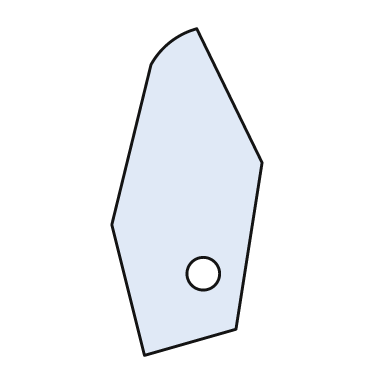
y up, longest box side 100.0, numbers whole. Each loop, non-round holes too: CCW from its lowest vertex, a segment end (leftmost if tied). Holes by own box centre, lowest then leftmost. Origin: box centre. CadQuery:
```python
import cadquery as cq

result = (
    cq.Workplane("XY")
    .moveTo(-13.0, -50.0)
    .lineTo(15.0, -42.0)
    .lineTo(23.0, 9.0)
    .lineTo(3.0, 50.0)
    .threePointArc((-5.0, 46.0), (-11.0, 39.0))
    .lineTo(-23.0, -10.0)
    .close()
    .moveTo(5.0, -25.0)
    .circle(5.0)
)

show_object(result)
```